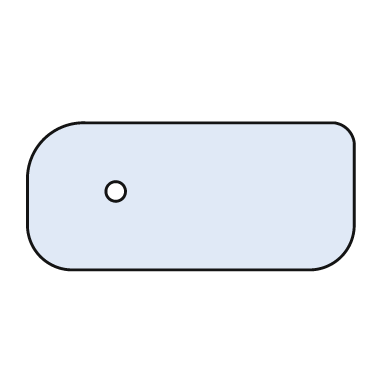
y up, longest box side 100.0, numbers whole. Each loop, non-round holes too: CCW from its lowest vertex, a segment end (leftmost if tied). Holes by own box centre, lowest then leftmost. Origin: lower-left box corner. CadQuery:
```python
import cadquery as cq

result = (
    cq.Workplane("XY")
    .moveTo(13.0, 0.0)
    .lineTo(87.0, 0.0)
    .threePointArc((96.0, 4.0), (100.0, 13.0))
    .lineTo(100.0, 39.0)
    .threePointArc((98.0, 43.0), (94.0, 45.0))
    .lineTo(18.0, 45.0)
    .threePointArc((5.0, 40.0), (0.0, 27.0))
    .lineTo(0.0, 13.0)
    .threePointArc((4.0, 4.0), (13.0, 0.0))
    .close()
    .moveTo(27.0, 24.0)
    .circle(3.0)
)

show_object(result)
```